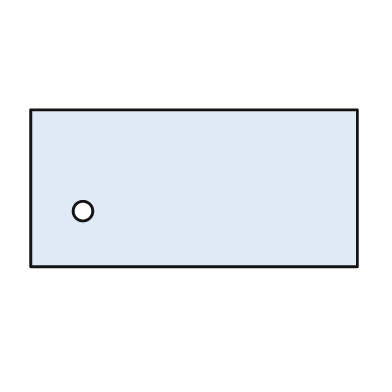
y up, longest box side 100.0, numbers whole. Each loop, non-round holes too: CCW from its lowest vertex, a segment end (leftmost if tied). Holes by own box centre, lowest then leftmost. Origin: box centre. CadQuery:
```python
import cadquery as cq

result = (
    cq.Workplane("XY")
    .moveTo(-50.0, -24.0)
    .lineTo(50.0, -24.0)
    .lineTo(50.0, 24.0)
    .lineTo(-50.0, 24.0)
    .close()
    .moveTo(-34.0, -7.0)
    .circle(3.0)
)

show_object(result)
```